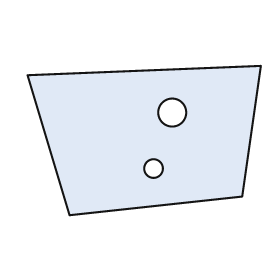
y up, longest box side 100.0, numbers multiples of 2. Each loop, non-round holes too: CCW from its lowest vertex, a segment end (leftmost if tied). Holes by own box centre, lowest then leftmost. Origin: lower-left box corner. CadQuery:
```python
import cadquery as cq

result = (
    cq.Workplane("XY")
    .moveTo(18.0, 0.0)
    .lineTo(92.0, 8.0)
    .lineTo(100.0, 64.0)
    .lineTo(0.0, 60.0)
    .close()
    .moveTo(54.0, 20.0)
    .circle(4.0)
    .moveTo(62.0, 44.0)
    .circle(6.0)
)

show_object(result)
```